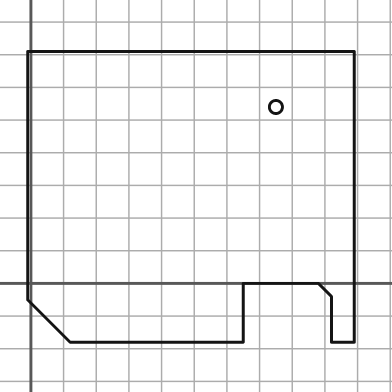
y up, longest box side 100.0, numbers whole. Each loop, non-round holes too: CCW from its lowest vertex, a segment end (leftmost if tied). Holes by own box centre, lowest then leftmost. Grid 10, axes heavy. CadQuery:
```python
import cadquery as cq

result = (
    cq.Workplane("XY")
    .moveTo(12.0, -18.0)
    .lineTo(65.0, -18.0)
    .lineTo(65.0, 0.0)
    .lineTo(88.0, 0.0)
    .lineTo(92.0, -4.0)
    .lineTo(92.0, -18.0)
    .lineTo(99.0, -18.0)
    .lineTo(99.0, 71.0)
    .lineTo(-1.0, 71.0)
    .lineTo(-1.0, -5.0)
    .close()
    .moveTo(75.0, 54.0)
    .circle(2.0)
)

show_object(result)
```